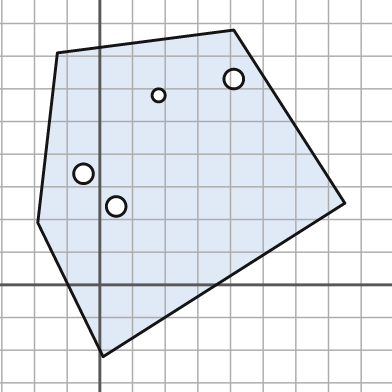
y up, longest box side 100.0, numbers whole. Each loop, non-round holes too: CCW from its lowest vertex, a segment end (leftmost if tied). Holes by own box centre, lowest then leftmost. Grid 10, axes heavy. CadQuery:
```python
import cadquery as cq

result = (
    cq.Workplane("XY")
    .moveTo(1.0, -22.0)
    .lineTo(75.0, 25.0)
    .lineTo(41.0, 78.0)
    .lineTo(-13.0, 71.0)
    .lineTo(-19.0, 19.0)
    .close()
    .moveTo(5.0, 24.0)
    .circle(3.0)
    .moveTo(-5.0, 34.0)
    .circle(3.0)
    .moveTo(18.0, 58.0)
    .circle(2.0)
    .moveTo(41.0, 63.0)
    .circle(3.0)
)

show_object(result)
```